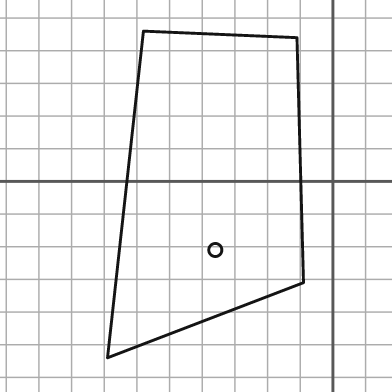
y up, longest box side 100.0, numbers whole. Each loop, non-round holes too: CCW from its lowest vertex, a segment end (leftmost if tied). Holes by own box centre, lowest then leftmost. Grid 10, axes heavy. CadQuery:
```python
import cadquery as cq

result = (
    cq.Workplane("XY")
    .moveTo(-69.0, -54.0)
    .lineTo(-9.0, -31.0)
    .lineTo(-11.0, 44.0)
    .lineTo(-58.0, 46.0)
    .close()
    .moveTo(-36.0, -21.0)
    .circle(2.0)
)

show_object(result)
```